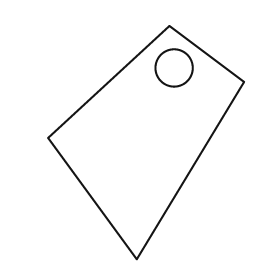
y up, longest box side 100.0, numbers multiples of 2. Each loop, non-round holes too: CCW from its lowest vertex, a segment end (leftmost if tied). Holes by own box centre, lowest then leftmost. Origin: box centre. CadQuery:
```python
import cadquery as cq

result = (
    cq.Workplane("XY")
    .moveTo(-4.0, -50.0)
    .lineTo(42.0, 26.0)
    .lineTo(10.0, 50.0)
    .lineTo(-42.0, 2.0)
    .close()
    .moveTo(12.0, 32.0)
    .circle(8.0)
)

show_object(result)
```